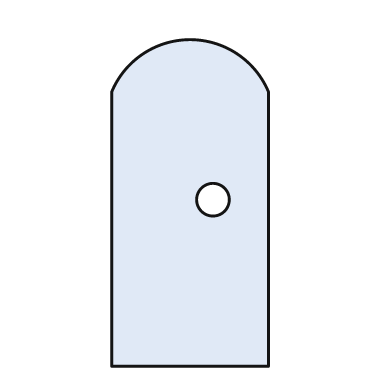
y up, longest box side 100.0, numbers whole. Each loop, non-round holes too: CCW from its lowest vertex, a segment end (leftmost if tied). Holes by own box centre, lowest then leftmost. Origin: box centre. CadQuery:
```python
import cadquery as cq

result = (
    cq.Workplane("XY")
    .moveTo(-24.0, -50.0)
    .lineTo(24.0, -50.0)
    .lineTo(24.0, 34.0)
    .threePointArc((0.0, 50.0), (-24.0, 34.0))
    .close()
    .moveTo(7.0, 1.0)
    .circle(5.0)
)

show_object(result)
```